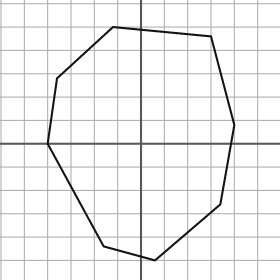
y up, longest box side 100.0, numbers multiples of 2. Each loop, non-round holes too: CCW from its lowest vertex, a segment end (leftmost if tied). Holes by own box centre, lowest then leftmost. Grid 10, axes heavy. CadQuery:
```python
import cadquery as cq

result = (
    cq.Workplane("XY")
    .moveTo(6.0, -50.0)
    .lineTo(34.0, -26.0)
    .lineTo(40.0, 8.0)
    .lineTo(30.0, 46.0)
    .lineTo(-12.0, 50.0)
    .lineTo(-36.0, 28.0)
    .lineTo(-40.0, 0.0)
    .lineTo(-16.0, -44.0)
    .close()
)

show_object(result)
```